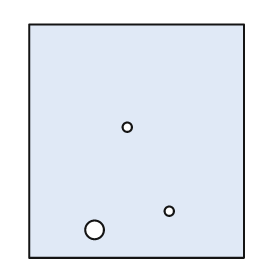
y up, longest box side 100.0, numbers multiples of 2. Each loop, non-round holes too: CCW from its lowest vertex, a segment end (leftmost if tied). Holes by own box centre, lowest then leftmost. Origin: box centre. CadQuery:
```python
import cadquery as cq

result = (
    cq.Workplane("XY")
    .moveTo(-46.0, -50.0)
    .lineTo(46.0, -50.0)
    .lineTo(46.0, 50.0)
    .lineTo(-46.0, 50.0)
    .close()
    .moveTo(-18.0, -38.0)
    .circle(4.0)
    .moveTo(14.0, -30.0)
    .circle(2.0)
    .moveTo(-4.0, 6.0)
    .circle(2.0)
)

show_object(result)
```